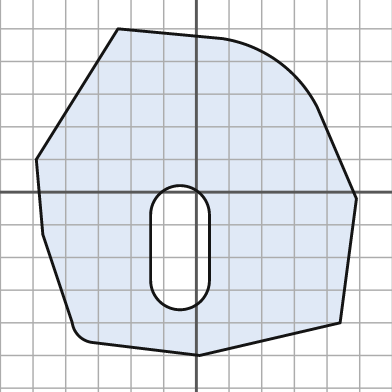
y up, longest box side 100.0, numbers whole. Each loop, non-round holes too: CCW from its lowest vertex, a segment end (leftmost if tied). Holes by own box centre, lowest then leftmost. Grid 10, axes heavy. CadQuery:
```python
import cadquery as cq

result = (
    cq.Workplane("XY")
    .moveTo(1.0, -50.0)
    .lineTo(44.0, -40.0)
    .lineTo(49.0, -2.0)
    .lineTo(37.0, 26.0)
    .threePointArc((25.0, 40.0), (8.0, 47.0))
    .lineTo(-24.0, 50.0)
    .lineTo(-49.0, 10.0)
    .lineTo(-47.0, -13.0)
    .lineTo(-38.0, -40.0)
    .threePointArc((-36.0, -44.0), (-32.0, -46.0))
    .close()
    .moveTo(-14.0, -27.0)
    .threePointArc((-5.0, -36.0), (4.0, -27.0))
    .lineTo(4.0, -7.0)
    .threePointArc((-5.0, 2.0), (-14.0, -7.0))
    .close()
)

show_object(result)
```